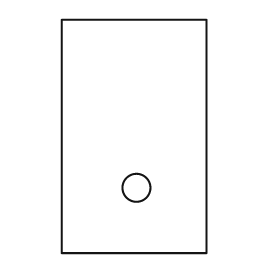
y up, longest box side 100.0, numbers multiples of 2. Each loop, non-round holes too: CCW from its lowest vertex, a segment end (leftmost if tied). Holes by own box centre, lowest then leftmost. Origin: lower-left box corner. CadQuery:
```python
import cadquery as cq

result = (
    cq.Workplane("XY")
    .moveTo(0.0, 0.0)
    .lineTo(62.0, 0.0)
    .lineTo(62.0, 100.0)
    .lineTo(0.0, 100.0)
    .close()
    .moveTo(32.0, 28.0)
    .circle(6.0)
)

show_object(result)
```